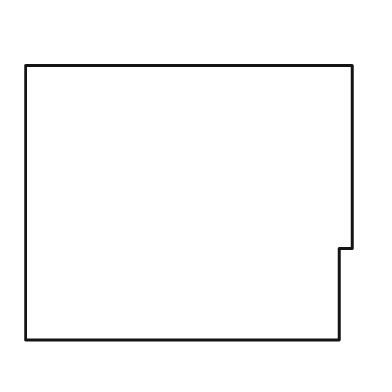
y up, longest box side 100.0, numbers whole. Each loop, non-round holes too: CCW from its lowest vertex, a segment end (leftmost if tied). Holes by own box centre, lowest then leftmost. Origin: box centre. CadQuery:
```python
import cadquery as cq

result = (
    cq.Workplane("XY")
    .moveTo(-50.0, -42.0)
    .lineTo(46.0, -42.0)
    .lineTo(46.0, -14.0)
    .lineTo(50.0, -14.0)
    .lineTo(50.0, 42.0)
    .lineTo(-50.0, 42.0)
    .close()
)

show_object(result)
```